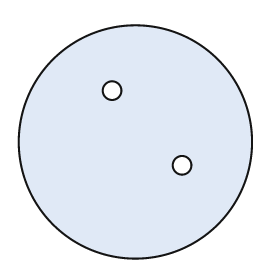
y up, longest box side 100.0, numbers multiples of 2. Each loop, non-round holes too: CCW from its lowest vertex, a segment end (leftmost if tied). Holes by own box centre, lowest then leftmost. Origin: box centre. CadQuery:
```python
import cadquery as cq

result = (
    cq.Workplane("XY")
    .moveTo(0.0, 0.0)
    .circle(50.0)
    .moveTo(20.0, -10.0)
    .circle(4.0)
    .moveTo(-10.0, 22.0)
    .circle(4.0)
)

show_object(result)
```